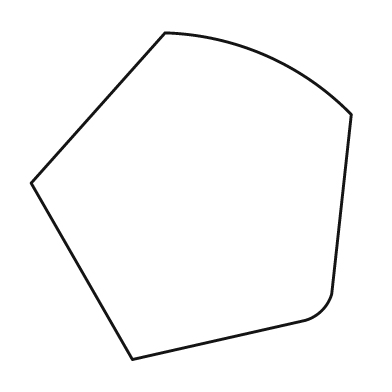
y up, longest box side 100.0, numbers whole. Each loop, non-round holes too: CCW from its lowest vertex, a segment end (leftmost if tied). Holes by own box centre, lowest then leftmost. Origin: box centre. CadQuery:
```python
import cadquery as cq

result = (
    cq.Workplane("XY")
    .moveTo(-18.0, -50.0)
    .lineTo(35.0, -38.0)
    .threePointArc((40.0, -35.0), (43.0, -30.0))
    .lineTo(49.0, 25.0)
    .threePointArc((23.0, 43.0), (-8.0, 50.0))
    .lineTo(-49.0, 4.0)
    .close()
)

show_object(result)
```